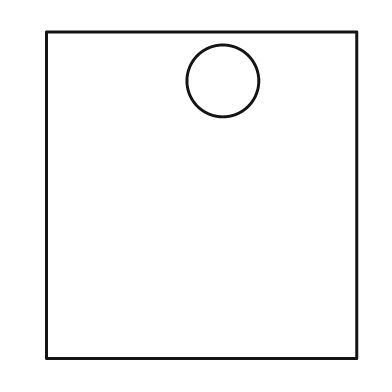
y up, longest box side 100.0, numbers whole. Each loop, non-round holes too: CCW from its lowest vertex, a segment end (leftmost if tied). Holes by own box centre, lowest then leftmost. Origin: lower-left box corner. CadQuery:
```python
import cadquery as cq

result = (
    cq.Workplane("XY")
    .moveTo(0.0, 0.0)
    .lineTo(95.0, 0.0)
    .lineTo(95.0, 100.0)
    .lineTo(0.0, 100.0)
    .close()
    .moveTo(54.0, 85.0)
    .circle(11.0)
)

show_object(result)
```